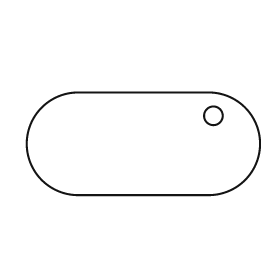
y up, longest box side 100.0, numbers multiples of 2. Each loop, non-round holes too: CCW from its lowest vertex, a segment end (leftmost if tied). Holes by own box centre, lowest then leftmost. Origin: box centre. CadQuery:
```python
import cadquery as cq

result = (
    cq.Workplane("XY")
    .moveTo(-28.0, -22.0)
    .lineTo(28.0, -22.0)
    .threePointArc((50.0, 0.0), (28.0, 22.0))
    .lineTo(-28.0, 22.0)
    .threePointArc((-50.0, 0.0), (-28.0, -22.0))
    .close()
    .moveTo(30.0, 12.0)
    .circle(4.0)
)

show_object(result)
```